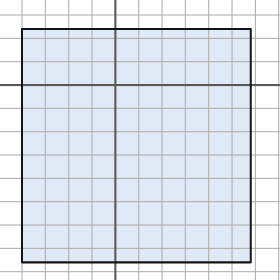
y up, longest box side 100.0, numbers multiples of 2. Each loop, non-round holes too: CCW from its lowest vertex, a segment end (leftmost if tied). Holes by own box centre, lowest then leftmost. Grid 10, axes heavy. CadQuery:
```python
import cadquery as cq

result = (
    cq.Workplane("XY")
    .moveTo(-40.0, -76.0)
    .lineTo(58.0, -76.0)
    .lineTo(58.0, 24.0)
    .lineTo(-40.0, 24.0)
    .close()
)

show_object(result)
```